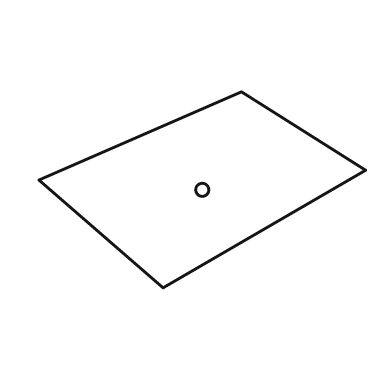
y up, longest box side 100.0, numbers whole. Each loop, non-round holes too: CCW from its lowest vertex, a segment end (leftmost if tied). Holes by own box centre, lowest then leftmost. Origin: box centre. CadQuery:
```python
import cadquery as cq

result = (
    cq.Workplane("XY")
    .moveTo(-12.0, -30.0)
    .lineTo(50.0, 6.0)
    .lineTo(12.0, 30.0)
    .lineTo(-50.0, 3.0)
    .close()
    .moveTo(0.0, 0.0)
    .circle(2.0)
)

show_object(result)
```